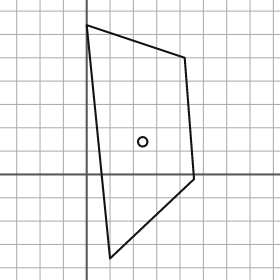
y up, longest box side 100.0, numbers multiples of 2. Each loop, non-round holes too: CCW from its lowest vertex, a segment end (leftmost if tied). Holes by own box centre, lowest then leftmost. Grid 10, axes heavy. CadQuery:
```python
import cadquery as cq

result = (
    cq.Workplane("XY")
    .moveTo(10.0, -36.0)
    .lineTo(46.0, -2.0)
    .lineTo(42.0, 50.0)
    .lineTo(0.0, 64.0)
    .close()
    .moveTo(24.0, 14.0)
    .circle(2.0)
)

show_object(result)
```